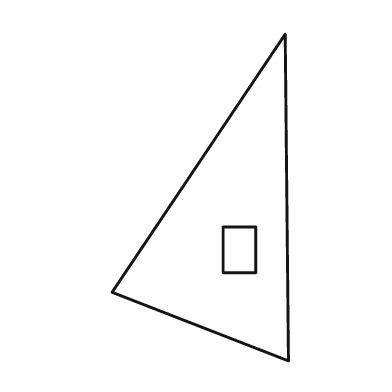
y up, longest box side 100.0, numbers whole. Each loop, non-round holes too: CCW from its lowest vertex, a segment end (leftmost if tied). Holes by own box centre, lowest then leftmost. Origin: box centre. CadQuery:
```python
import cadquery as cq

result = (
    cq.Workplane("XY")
    .moveTo(27.0, -50.0)
    .lineTo(26.0, 50.0)
    .lineTo(-27.0, -29.0)
    .close()
    .moveTo(7.0, -23.0)
    .lineTo(17.0, -23.0)
    .lineTo(17.0, -9.0)
    .lineTo(7.0, -9.0)
    .close()
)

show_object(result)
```